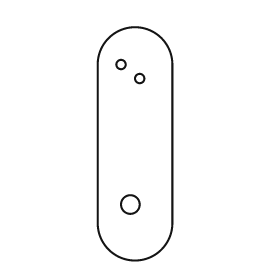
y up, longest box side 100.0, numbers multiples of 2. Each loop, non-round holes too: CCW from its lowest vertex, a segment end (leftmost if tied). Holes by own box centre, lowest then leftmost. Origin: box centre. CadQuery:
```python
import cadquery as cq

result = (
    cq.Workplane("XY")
    .moveTo(-16.0, -34.0)
    .threePointArc((0.0, -50.0), (16.0, -34.0))
    .lineTo(16.0, 34.0)
    .threePointArc((0.0, 50.0), (-16.0, 34.0))
    .close()
    .moveTo(-2.0, -26.0)
    .circle(4.0)
    .moveTo(2.0, 28.0)
    .circle(2.0)
    .moveTo(-6.0, 34.0)
    .circle(2.0)
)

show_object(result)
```